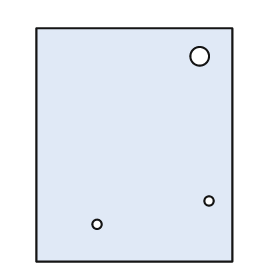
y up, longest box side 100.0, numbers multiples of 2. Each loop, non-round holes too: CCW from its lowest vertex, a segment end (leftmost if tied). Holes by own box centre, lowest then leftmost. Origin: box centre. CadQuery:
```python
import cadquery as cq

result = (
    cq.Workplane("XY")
    .moveTo(-42.0, -50.0)
    .lineTo(42.0, -50.0)
    .lineTo(42.0, 50.0)
    .lineTo(-42.0, 50.0)
    .close()
    .moveTo(-16.0, -34.0)
    .circle(2.0)
    .moveTo(32.0, -24.0)
    .circle(2.0)
    .moveTo(28.0, 38.0)
    .circle(4.0)
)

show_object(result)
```